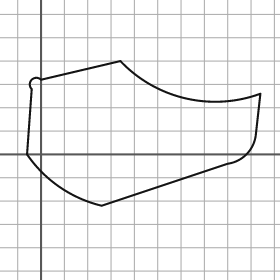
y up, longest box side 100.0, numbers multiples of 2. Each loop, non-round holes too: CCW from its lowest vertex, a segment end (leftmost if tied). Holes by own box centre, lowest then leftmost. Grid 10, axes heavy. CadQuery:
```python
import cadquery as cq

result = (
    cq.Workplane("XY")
    .moveTo(26.0, -22.0)
    .lineTo(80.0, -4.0)
    .threePointArc((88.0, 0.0), (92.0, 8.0))
    .lineTo(94.0, 26.0)
    .threePointArc((62.0, 24.0), (34.0, 40.0))
    .lineTo(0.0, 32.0)
    .threePointArc((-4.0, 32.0), (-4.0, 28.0))
    .lineTo(-6.0, 0.0)
    .threePointArc((8.0, -14.0), (26.0, -22.0))
    .close()
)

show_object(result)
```